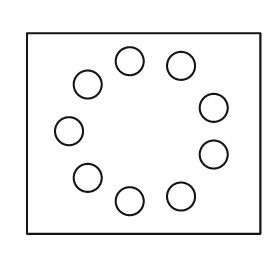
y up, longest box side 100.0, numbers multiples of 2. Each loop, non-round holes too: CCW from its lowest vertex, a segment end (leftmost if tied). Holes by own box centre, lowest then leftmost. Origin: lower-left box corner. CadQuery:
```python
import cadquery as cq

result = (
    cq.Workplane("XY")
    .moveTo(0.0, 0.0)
    .lineTo(100.0, 0.0)
    .lineTo(100.0, 86.0)
    .lineTo(0.0, 86.0)
    .close()
    .moveTo(44.0, 14.0)
    .circle(6.0)
    .moveTo(66.0, 16.0)
    .circle(6.0)
    .moveTo(26.0, 24.0)
    .circle(6.0)
    .moveTo(80.0, 34.0)
    .circle(6.0)
    .moveTo(18.0, 44.0)
    .circle(6.0)
    .moveTo(80.0, 54.0)
    .circle(6.0)
    .moveTo(26.0, 64.0)
    .circle(6.0)
    .moveTo(66.0, 72.0)
    .circle(6.0)
    .moveTo(44.0, 74.0)
    .circle(6.0)
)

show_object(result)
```